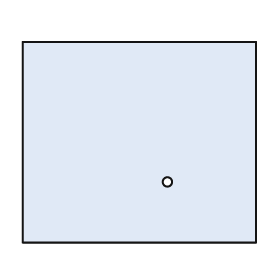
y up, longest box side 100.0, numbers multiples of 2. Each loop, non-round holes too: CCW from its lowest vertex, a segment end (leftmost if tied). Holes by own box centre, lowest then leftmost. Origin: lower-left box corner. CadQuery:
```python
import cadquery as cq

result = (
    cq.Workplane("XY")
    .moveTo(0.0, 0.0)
    .lineTo(100.0, 0.0)
    .lineTo(100.0, 86.0)
    .lineTo(0.0, 86.0)
    .close()
    .moveTo(62.0, 26.0)
    .circle(2.0)
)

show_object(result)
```